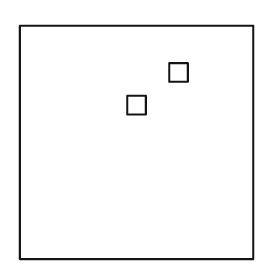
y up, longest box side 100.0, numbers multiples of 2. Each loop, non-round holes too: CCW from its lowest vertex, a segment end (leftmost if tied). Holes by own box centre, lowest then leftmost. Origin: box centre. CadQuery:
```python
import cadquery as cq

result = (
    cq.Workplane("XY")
    .moveTo(-50.0, -50.0)
    .lineTo(50.0, -50.0)
    .lineTo(50.0, 50.0)
    .lineTo(-50.0, 50.0)
    .close()
    .moveTo(-4.0, 12.0)
    .lineTo(4.0, 12.0)
    .lineTo(4.0, 20.0)
    .lineTo(-4.0, 20.0)
    .close()
    .moveTo(14.0, 26.0)
    .lineTo(22.0, 26.0)
    .lineTo(22.0, 34.0)
    .lineTo(14.0, 34.0)
    .close()
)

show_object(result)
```